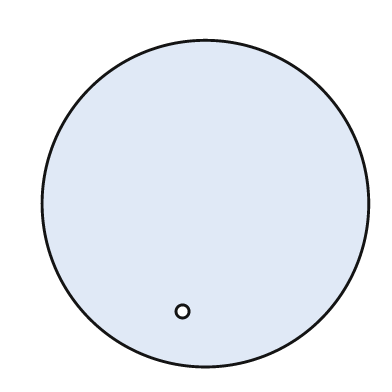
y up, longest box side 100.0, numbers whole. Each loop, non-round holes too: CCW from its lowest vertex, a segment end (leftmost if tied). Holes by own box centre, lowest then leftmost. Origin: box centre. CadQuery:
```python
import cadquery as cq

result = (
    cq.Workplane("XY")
    .moveTo(0.0, 0.0)
    .circle(50.0)
    .moveTo(-7.0, -33.0)
    .circle(2.0)
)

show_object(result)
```